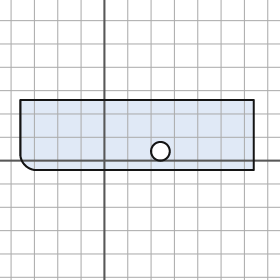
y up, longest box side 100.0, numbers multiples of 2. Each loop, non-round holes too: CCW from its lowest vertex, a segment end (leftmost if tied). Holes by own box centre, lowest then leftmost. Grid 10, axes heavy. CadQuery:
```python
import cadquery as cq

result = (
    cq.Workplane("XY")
    .moveTo(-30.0, -4.0)
    .lineTo(64.0, -4.0)
    .lineTo(64.0, 26.0)
    .lineTo(-36.0, 26.0)
    .lineTo(-36.0, 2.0)
    .threePointArc((-34.0, -2.0), (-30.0, -4.0))
    .close()
    .moveTo(24.0, 4.0)
    .circle(4.0)
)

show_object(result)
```